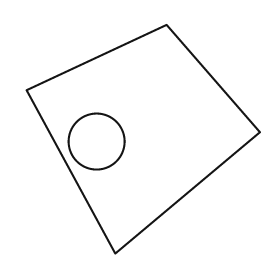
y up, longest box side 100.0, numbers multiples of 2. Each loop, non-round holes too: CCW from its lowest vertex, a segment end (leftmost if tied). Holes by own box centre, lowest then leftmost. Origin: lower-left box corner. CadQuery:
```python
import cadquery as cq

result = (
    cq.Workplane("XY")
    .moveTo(38.0, 0.0)
    .lineTo(100.0, 52.0)
    .lineTo(60.0, 98.0)
    .lineTo(0.0, 70.0)
    .close()
    .moveTo(30.0, 48.0)
    .circle(12.0)
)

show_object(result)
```